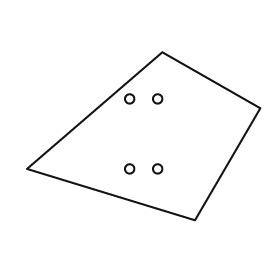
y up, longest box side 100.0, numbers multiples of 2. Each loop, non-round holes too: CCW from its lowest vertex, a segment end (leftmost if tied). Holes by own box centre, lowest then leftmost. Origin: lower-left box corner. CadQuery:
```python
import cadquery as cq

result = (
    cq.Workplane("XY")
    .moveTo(72.0, 0.0)
    .lineTo(100.0, 48.0)
    .lineTo(58.0, 72.0)
    .lineTo(0.0, 22.0)
    .close()
    .moveTo(44.0, 22.0)
    .circle(2.0)
    .moveTo(56.0, 22.0)
    .circle(2.0)
    .moveTo(44.0, 52.0)
    .circle(2.0)
    .moveTo(56.0, 52.0)
    .circle(2.0)
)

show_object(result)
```